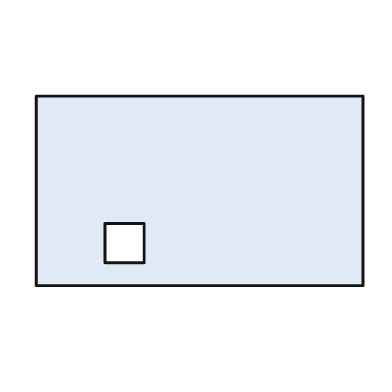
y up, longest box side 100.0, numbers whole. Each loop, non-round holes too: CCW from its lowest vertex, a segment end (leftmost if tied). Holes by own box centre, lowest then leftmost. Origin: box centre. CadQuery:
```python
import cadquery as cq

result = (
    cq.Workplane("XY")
    .moveTo(-50.0, -29.0)
    .lineTo(50.0, -29.0)
    .lineTo(50.0, 29.0)
    .lineTo(-50.0, 29.0)
    .close()
    .moveTo(-29.0, -22.0)
    .lineTo(-17.0, -22.0)
    .lineTo(-17.0, -10.0)
    .lineTo(-29.0, -10.0)
    .close()
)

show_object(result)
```